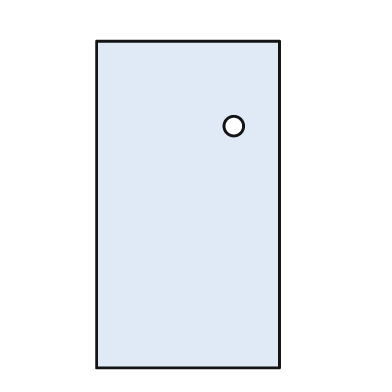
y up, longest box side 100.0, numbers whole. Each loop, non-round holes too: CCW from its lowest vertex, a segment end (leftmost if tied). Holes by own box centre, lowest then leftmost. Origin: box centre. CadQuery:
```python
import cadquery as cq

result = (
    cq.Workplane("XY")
    .moveTo(-28.0, -50.0)
    .lineTo(28.0, -50.0)
    .lineTo(28.0, 50.0)
    .lineTo(-28.0, 50.0)
    .close()
    .moveTo(14.0, 24.0)
    .circle(3.0)
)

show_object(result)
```